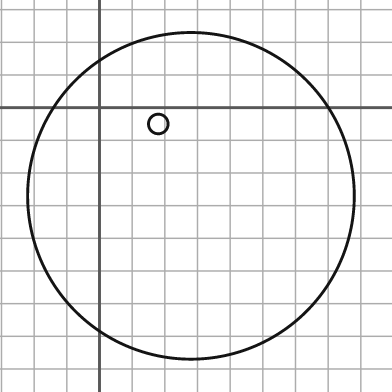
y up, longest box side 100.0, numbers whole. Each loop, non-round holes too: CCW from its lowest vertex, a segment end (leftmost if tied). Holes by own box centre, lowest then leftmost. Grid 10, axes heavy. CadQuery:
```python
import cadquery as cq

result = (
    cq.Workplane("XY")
    .moveTo(28.0, -27.0)
    .circle(50.0)
    .moveTo(18.0, -5.0)
    .circle(3.0)
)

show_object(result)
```